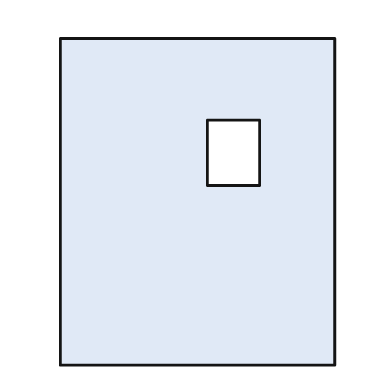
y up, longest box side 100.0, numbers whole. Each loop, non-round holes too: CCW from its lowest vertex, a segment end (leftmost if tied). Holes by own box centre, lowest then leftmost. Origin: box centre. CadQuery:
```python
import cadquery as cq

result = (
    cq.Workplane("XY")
    .moveTo(-42.0, -50.0)
    .lineTo(42.0, -50.0)
    .lineTo(42.0, 50.0)
    .lineTo(-42.0, 50.0)
    .close()
    .moveTo(3.0, 5.0)
    .lineTo(19.0, 5.0)
    .lineTo(19.0, 25.0)
    .lineTo(3.0, 25.0)
    .close()
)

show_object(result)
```